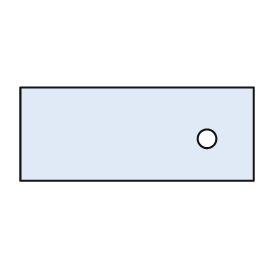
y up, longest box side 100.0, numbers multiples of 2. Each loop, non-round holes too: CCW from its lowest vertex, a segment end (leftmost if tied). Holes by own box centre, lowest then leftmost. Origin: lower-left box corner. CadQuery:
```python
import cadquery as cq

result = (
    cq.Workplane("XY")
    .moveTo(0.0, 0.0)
    .lineTo(100.0, 0.0)
    .lineTo(100.0, 40.0)
    .lineTo(0.0, 40.0)
    .close()
    .moveTo(80.0, 18.0)
    .circle(4.0)
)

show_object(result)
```